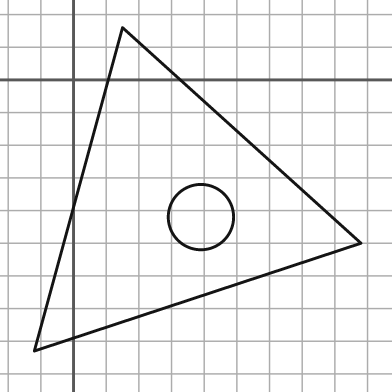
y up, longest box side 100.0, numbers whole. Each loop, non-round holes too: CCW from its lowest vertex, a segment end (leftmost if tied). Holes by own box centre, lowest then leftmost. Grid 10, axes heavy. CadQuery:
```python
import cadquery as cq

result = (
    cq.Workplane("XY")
    .moveTo(-12.0, -83.0)
    .lineTo(88.0, -50.0)
    .lineTo(15.0, 16.0)
    .close()
    .moveTo(39.0, -42.0)
    .circle(10.0)
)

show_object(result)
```